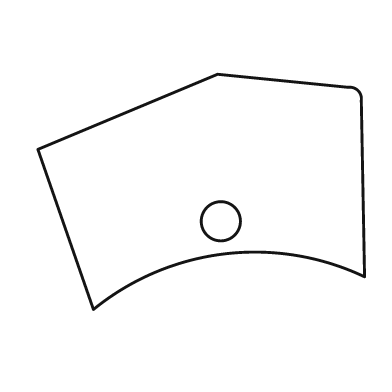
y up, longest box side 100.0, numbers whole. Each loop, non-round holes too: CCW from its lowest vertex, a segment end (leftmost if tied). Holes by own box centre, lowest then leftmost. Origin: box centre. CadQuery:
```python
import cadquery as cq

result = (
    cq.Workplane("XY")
    .moveTo(-33.0, -36.0)
    .threePointArc((7.0, -19.0), (50.0, -26.0))
    .lineTo(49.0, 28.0)
    .threePointArc((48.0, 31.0), (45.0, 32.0))
    .lineTo(5.0, 36.0)
    .lineTo(-50.0, 13.0)
    .close()
    .moveTo(6.0, -9.0)
    .circle(6.0)
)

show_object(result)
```